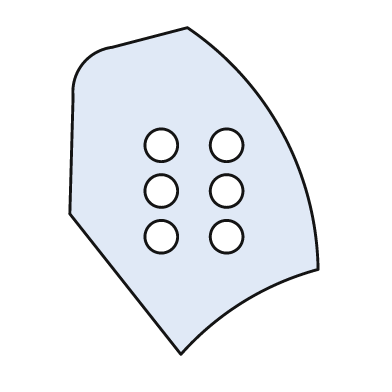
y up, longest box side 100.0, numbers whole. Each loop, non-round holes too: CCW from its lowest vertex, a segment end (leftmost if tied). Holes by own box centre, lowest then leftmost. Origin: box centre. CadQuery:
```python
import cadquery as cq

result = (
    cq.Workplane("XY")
    .moveTo(-4.0, -50.0)
    .threePointArc((15.0, -34.0), (38.0, -24.0))
    .threePointArc((27.0, 18.0), (-2.0, 50.0))
    .lineTo(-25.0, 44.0)
    .threePointArc((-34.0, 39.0), (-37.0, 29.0))
    .lineTo(-38.0, -7.0)
    .close()
    .moveTo(-10.0, -14.0)
    .circle(5.0)
    .moveTo(10.0, -14.0)
    .circle(5.0)
    .moveTo(-10.0, 0.0)
    .circle(5.0)
    .moveTo(10.0, 0.0)
    .circle(5.0)
    .moveTo(-10.0, 14.0)
    .circle(5.0)
    .moveTo(10.0, 14.0)
    .circle(5.0)
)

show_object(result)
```